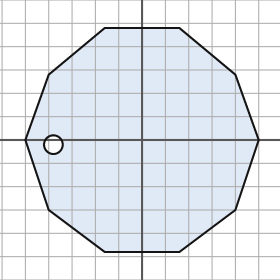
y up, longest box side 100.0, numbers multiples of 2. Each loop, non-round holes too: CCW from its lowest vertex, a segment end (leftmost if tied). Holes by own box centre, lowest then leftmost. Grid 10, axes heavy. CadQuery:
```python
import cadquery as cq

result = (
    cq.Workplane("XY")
    .moveTo(-16.0, -48.0)
    .lineTo(16.0, -48.0)
    .lineTo(40.0, -30.0)
    .lineTo(50.0, 0.0)
    .lineTo(40.0, 28.0)
    .lineTo(16.0, 48.0)
    .lineTo(-16.0, 48.0)
    .lineTo(-40.0, 28.0)
    .lineTo(-50.0, 0.0)
    .lineTo(-40.0, -30.0)
    .close()
    .moveTo(-38.0, -2.0)
    .circle(4.0)
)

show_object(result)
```